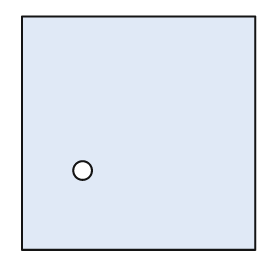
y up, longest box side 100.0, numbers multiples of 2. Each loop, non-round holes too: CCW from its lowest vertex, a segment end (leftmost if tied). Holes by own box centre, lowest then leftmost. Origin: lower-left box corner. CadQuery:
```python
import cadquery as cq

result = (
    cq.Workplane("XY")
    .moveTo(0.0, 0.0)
    .lineTo(100.0, 0.0)
    .lineTo(100.0, 100.0)
    .lineTo(0.0, 100.0)
    .close()
    .moveTo(26.0, 34.0)
    .circle(4.0)
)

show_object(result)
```